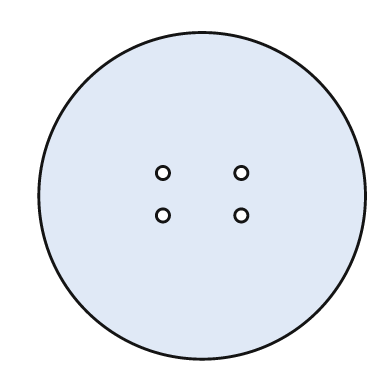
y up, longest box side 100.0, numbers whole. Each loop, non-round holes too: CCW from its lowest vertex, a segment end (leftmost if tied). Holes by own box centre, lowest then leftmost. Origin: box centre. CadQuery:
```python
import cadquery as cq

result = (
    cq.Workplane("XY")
    .moveTo(0.0, 0.0)
    .circle(50.0)
    .moveTo(-12.0, -6.0)
    .circle(2.0)
    .moveTo(12.0, -6.0)
    .circle(2.0)
    .moveTo(-12.0, 7.0)
    .circle(2.0)
    .moveTo(12.0, 7.0)
    .circle(2.0)
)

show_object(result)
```